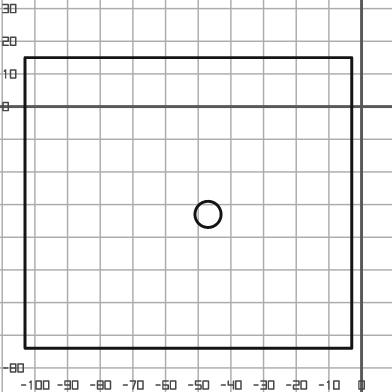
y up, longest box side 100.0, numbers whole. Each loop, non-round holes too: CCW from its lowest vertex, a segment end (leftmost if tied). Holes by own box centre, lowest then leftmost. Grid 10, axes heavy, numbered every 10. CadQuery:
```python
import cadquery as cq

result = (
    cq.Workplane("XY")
    .moveTo(-103.0, -74.0)
    .lineTo(-3.0, -74.0)
    .lineTo(-3.0, 15.0)
    .lineTo(-103.0, 15.0)
    .close()
    .moveTo(-47.0, -33.0)
    .circle(4.0)
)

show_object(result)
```